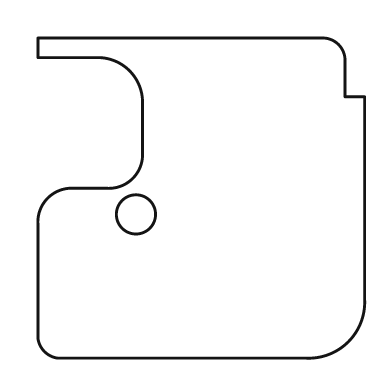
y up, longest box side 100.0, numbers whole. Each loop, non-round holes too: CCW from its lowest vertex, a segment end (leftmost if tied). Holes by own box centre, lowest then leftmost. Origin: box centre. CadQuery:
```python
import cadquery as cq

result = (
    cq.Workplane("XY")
    .moveTo(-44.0, -49.0)
    .lineTo(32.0, -49.0)
    .threePointArc((45.0, -44.0), (50.0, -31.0))
    .lineTo(50.0, 31.0)
    .lineTo(44.0, 31.0)
    .lineTo(44.0, 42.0)
    .threePointArc((42.0, 47.0), (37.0, 49.0))
    .lineTo(-50.0, 49.0)
    .lineTo(-50.0, 43.0)
    .lineTo(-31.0, 43.0)
    .threePointArc((-22.0, 39.0), (-18.0, 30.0))
    .lineTo(-18.0, 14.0)
    .threePointArc((-21.0, 6.0), (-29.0, 3.0))
    .lineTo(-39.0, 3.0)
    .threePointArc((-47.0, 0.0), (-50.0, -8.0))
    .lineTo(-50.0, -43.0)
    .threePointArc((-48.0, -47.0), (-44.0, -49.0))
    .close()
    .moveTo(-20.0, -5.0)
    .circle(6.0)
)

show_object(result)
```